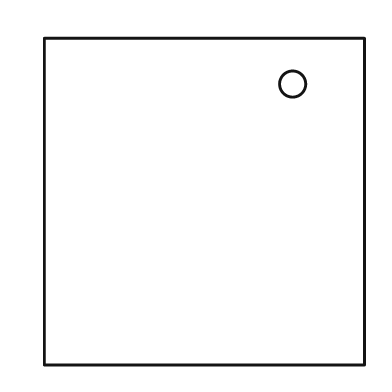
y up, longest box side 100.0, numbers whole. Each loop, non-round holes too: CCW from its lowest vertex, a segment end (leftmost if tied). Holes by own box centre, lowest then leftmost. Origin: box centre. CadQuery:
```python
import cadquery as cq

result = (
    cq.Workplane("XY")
    .moveTo(-49.0, -50.0)
    .lineTo(49.0, -50.0)
    .lineTo(49.0, 50.0)
    .lineTo(-49.0, 50.0)
    .close()
    .moveTo(27.0, 36.0)
    .circle(4.0)
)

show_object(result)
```